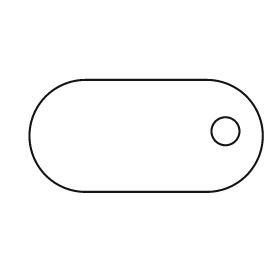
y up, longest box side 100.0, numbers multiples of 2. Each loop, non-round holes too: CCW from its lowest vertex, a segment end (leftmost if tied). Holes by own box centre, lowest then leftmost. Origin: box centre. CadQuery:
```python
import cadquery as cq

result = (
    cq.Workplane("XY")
    .moveTo(-26.0, -24.0)
    .lineTo(26.0, -24.0)
    .threePointArc((50.0, 0.0), (26.0, 24.0))
    .lineTo(-26.0, 24.0)
    .threePointArc((-50.0, 0.0), (-26.0, -24.0))
    .close()
    .moveTo(34.0, 2.0)
    .circle(6.0)
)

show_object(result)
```